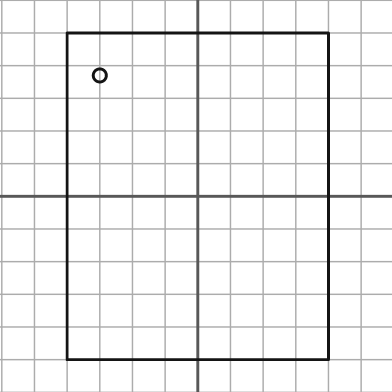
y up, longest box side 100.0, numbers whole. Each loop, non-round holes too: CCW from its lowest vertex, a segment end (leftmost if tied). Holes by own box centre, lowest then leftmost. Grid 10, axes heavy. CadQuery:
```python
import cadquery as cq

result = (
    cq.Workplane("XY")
    .moveTo(-40.0, -50.0)
    .lineTo(40.0, -50.0)
    .lineTo(40.0, 50.0)
    .lineTo(-40.0, 50.0)
    .close()
    .moveTo(-30.0, 37.0)
    .circle(2.0)
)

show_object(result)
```